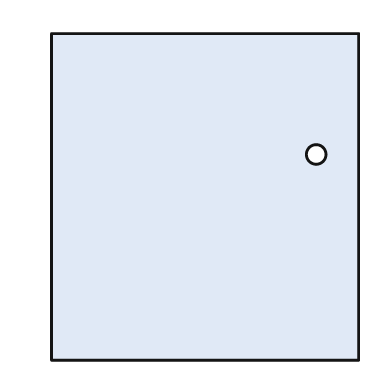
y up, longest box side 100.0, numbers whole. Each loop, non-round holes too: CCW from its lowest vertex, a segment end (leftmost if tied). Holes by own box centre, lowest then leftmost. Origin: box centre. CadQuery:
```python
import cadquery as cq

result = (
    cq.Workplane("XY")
    .moveTo(-47.0, -50.0)
    .lineTo(47.0, -50.0)
    .lineTo(47.0, 50.0)
    .lineTo(-47.0, 50.0)
    .close()
    .moveTo(34.0, 13.0)
    .circle(3.0)
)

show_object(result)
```